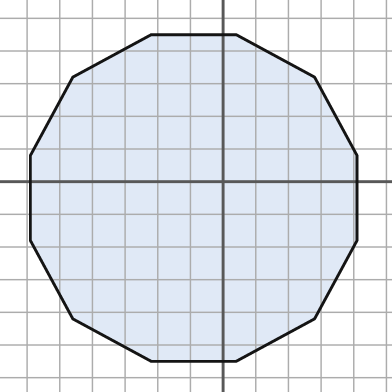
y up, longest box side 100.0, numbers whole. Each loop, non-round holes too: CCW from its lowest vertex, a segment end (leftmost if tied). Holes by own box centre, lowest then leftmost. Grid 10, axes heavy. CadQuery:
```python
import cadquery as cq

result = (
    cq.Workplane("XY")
    .moveTo(-22.0, -55.0)
    .lineTo(4.0, -55.0)
    .lineTo(28.0, -42.0)
    .lineTo(41.0, -18.0)
    .lineTo(41.0, 8.0)
    .lineTo(28.0, 32.0)
    .lineTo(4.0, 45.0)
    .lineTo(-22.0, 45.0)
    .lineTo(-46.0, 32.0)
    .lineTo(-59.0, 8.0)
    .lineTo(-59.0, -18.0)
    .lineTo(-46.0, -42.0)
    .close()
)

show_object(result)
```